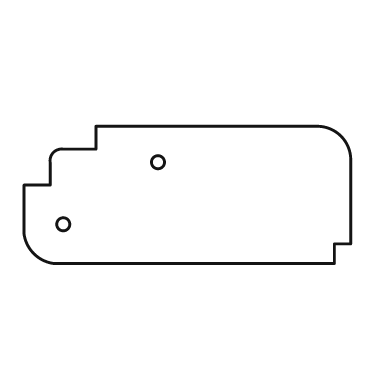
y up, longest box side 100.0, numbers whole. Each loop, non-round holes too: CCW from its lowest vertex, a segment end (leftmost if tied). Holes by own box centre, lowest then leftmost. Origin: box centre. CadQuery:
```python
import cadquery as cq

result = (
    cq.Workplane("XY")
    .moveTo(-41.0, -21.0)
    .lineTo(45.0, -21.0)
    .lineTo(45.0, -15.0)
    .lineTo(50.0, -15.0)
    .lineTo(50.0, 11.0)
    .threePointArc((47.0, 18.0), (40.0, 21.0))
    .lineTo(-28.0, 21.0)
    .lineTo(-28.0, 14.0)
    .lineTo(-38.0, 14.0)
    .threePointArc((-41.0, 13.0), (-42.0, 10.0))
    .lineTo(-42.0, 3.0)
    .lineTo(-50.0, 3.0)
    .lineTo(-50.0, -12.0)
    .threePointArc((-47.0, -18.0), (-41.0, -21.0))
    .close()
    .moveTo(-38.0, -9.0)
    .circle(2.0)
    .moveTo(-9.0, 10.0)
    .circle(2.0)
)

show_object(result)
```